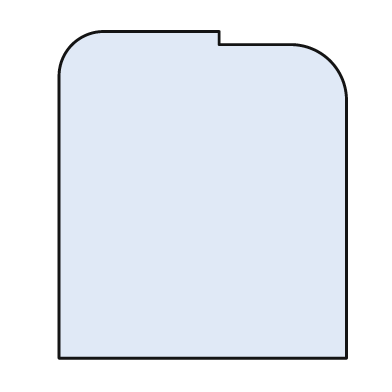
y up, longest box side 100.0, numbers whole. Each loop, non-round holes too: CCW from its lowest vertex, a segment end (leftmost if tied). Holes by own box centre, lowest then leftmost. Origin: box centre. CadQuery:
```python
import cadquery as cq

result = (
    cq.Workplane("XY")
    .moveTo(-44.0, -50.0)
    .lineTo(44.0, -50.0)
    .lineTo(44.0, 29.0)
    .threePointArc((39.0, 41.0), (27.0, 46.0))
    .lineTo(5.0, 46.0)
    .lineTo(5.0, 50.0)
    .lineTo(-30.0, 50.0)
    .threePointArc((-40.0, 46.0), (-44.0, 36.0))
    .close()
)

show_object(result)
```